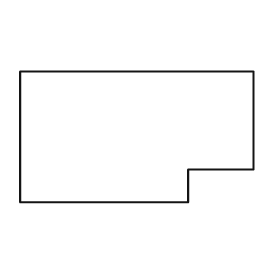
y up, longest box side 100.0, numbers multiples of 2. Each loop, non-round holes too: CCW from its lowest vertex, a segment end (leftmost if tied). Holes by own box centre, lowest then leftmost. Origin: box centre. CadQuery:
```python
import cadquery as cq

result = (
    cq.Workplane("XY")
    .moveTo(-50.0, -28.0)
    .lineTo(22.0, -28.0)
    .lineTo(22.0, -14.0)
    .lineTo(50.0, -14.0)
    .lineTo(50.0, 28.0)
    .lineTo(-50.0, 28.0)
    .close()
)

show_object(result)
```